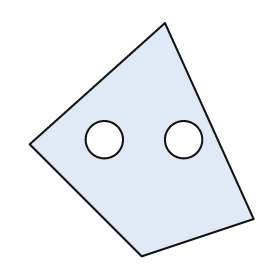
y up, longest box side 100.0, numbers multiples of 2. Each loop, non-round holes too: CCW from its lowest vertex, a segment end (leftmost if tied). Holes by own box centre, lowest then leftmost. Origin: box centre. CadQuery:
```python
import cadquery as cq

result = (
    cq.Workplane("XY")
    .moveTo(0.0, -50.0)
    .lineTo(48.0, -34.0)
    .lineTo(10.0, 50.0)
    .lineTo(-48.0, -2.0)
    .close()
    .moveTo(-16.0, 0.0)
    .circle(8.0)
    .moveTo(18.0, 0.0)
    .circle(8.0)
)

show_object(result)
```